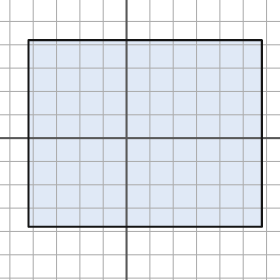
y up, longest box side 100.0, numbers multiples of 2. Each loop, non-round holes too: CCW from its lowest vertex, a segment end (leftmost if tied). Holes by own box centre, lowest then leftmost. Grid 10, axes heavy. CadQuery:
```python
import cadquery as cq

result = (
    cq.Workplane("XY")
    .moveTo(-42.0, -38.0)
    .lineTo(58.0, -38.0)
    .lineTo(58.0, 42.0)
    .lineTo(-42.0, 42.0)
    .close()
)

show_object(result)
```